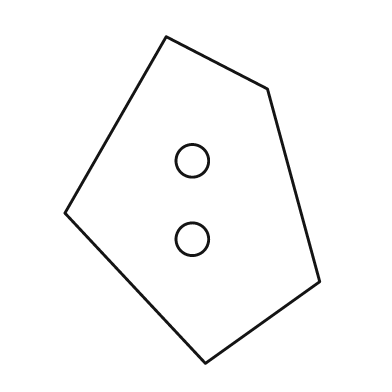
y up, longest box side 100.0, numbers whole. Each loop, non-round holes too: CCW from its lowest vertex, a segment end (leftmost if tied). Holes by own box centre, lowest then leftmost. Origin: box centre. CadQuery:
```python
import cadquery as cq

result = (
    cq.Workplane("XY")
    .moveTo(4.0, -50.0)
    .lineTo(39.0, -25.0)
    .lineTo(23.0, 34.0)
    .lineTo(-8.0, 50.0)
    .lineTo(-39.0, -4.0)
    .close()
    .moveTo(0.0, -12.0)
    .circle(5.0)
    .moveTo(0.0, 12.0)
    .circle(5.0)
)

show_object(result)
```